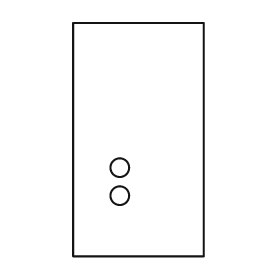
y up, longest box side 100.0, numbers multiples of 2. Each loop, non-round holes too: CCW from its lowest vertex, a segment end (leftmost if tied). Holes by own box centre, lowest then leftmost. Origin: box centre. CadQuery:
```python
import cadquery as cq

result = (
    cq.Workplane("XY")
    .moveTo(-28.0, -50.0)
    .lineTo(28.0, -50.0)
    .lineTo(28.0, 50.0)
    .lineTo(-28.0, 50.0)
    .close()
    .moveTo(-8.0, -24.0)
    .circle(4.0)
    .moveTo(-8.0, -12.0)
    .circle(4.0)
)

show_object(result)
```